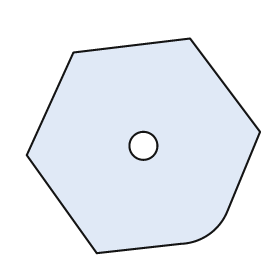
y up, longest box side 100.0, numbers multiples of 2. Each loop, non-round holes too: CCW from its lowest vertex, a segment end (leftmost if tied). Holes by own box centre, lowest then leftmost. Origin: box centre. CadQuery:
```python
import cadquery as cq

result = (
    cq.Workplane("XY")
    .moveTo(-20.0, -46.0)
    .lineTo(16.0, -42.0)
    .threePointArc((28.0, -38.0), (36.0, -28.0))
    .lineTo(50.0, 6.0)
    .lineTo(20.0, 46.0)
    .lineTo(-30.0, 40.0)
    .lineTo(-50.0, -4.0)
    .close()
    .moveTo(0.0, 0.0)
    .circle(6.0)
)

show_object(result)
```